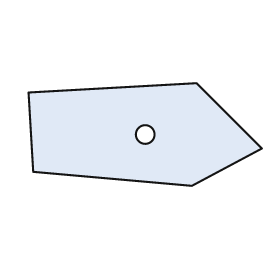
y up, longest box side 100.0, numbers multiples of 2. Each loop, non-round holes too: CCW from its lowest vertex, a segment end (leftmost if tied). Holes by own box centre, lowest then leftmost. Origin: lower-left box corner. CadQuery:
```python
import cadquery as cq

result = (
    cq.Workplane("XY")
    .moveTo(70.0, 0.0)
    .lineTo(100.0, 16.0)
    .lineTo(72.0, 44.0)
    .lineTo(0.0, 40.0)
    .lineTo(2.0, 6.0)
    .close()
    .moveTo(50.0, 22.0)
    .circle(4.0)
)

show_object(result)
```